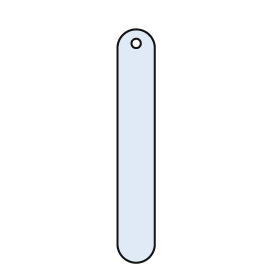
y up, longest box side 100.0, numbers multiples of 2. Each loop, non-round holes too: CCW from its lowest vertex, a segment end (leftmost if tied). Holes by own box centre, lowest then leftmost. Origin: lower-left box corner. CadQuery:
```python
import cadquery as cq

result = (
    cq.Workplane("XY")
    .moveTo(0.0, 8.0)
    .threePointArc((8.0, 0.0), (16.0, 8.0))
    .lineTo(16.0, 92.0)
    .threePointArc((8.0, 100.0), (0.0, 92.0))
    .close()
    .moveTo(8.0, 94.0)
    .circle(2.0)
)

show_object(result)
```